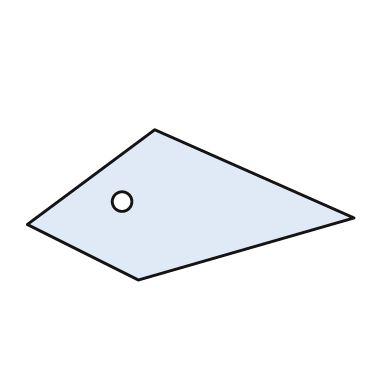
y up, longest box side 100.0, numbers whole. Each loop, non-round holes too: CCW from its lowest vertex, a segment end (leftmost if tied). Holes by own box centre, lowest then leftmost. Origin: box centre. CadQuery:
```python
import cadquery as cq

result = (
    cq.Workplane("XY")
    .moveTo(-16.0, -23.0)
    .lineTo(50.0, -4.0)
    .lineTo(-11.0, 23.0)
    .lineTo(-50.0, -6.0)
    .close()
    .moveTo(-21.0, 1.0)
    .circle(3.0)
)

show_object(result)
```